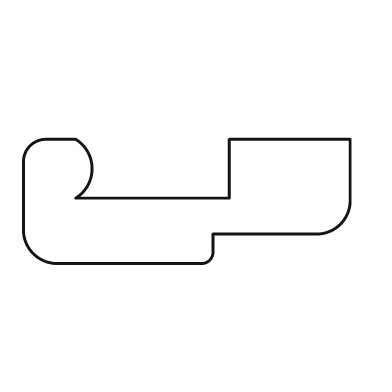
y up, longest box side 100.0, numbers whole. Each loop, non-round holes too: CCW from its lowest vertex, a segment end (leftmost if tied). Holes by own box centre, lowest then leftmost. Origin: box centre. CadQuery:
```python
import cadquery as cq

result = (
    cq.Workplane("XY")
    .moveTo(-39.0, -19.0)
    .lineTo(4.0, -19.0)
    .threePointArc((7.0, -18.0), (8.0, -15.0))
    .lineTo(8.0, -10.0)
    .lineTo(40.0, -10.0)
    .threePointArc((47.0, -7.0), (50.0, 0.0))
    .lineTo(50.0, 19.0)
    .lineTo(13.0, 19.0)
    .lineTo(13.0, 1.0)
    .lineTo(-34.0, 1.0)
    .threePointArc((-29.0, 10.0), (-34.0, 19.0))
    .lineTo(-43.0, 19.0)
    .threePointArc((-48.0, 17.0), (-50.0, 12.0))
    .lineTo(-50.0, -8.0)
    .threePointArc((-47.0, -16.0), (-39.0, -19.0))
    .close()
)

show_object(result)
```